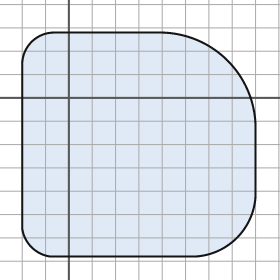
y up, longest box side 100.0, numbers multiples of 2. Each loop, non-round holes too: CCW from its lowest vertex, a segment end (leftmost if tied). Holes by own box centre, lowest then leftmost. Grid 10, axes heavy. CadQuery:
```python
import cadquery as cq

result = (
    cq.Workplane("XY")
    .moveTo(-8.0, -68.0)
    .lineTo(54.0, -68.0)
    .threePointArc((72.0, -60.0), (80.0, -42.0))
    .lineTo(80.0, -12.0)
    .threePointArc((68.0, 16.0), (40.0, 28.0))
    .lineTo(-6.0, 28.0)
    .threePointArc((-16.0, 24.0), (-20.0, 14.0))
    .lineTo(-20.0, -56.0)
    .threePointArc((-16.0, -64.0), (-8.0, -68.0))
    .close()
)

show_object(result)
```